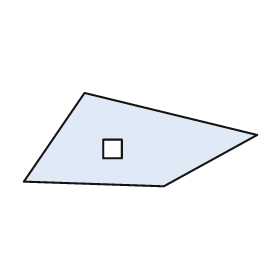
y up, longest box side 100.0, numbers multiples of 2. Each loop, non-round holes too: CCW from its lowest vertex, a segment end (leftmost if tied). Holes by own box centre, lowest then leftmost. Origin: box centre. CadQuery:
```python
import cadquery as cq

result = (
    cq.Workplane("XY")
    .moveTo(10.0, -20.0)
    .lineTo(50.0, 2.0)
    .lineTo(-24.0, 20.0)
    .lineTo(-50.0, -18.0)
    .close()
    .moveTo(-16.0, -8.0)
    .lineTo(-8.0, -8.0)
    .lineTo(-8.0, 0.0)
    .lineTo(-16.0, 0.0)
    .close()
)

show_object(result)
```